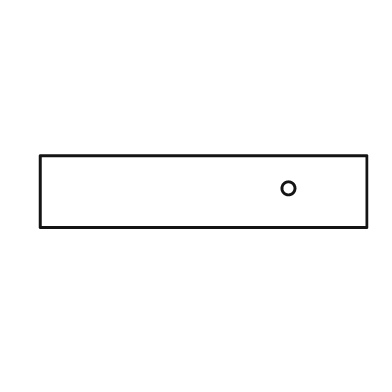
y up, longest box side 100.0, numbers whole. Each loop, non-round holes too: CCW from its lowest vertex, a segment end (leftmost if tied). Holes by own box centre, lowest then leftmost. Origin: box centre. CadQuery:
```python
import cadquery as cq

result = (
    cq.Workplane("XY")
    .moveTo(-50.0, -11.0)
    .lineTo(50.0, -11.0)
    .lineTo(50.0, 11.0)
    .lineTo(-50.0, 11.0)
    .close()
    .moveTo(26.0, 1.0)
    .circle(2.0)
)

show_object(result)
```